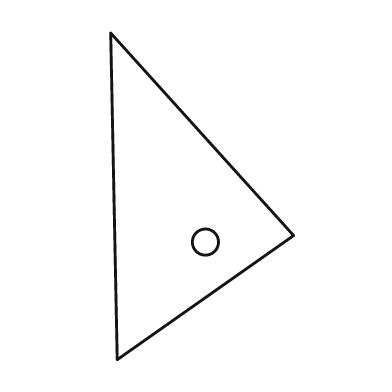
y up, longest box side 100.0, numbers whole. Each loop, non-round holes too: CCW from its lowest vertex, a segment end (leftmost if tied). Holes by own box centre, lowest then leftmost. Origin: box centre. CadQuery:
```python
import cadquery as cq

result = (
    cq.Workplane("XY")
    .moveTo(-26.0, -50.0)
    .lineTo(28.0, -12.0)
    .lineTo(-28.0, 50.0)
    .close()
    .moveTo(1.0, -14.0)
    .circle(4.0)
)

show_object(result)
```